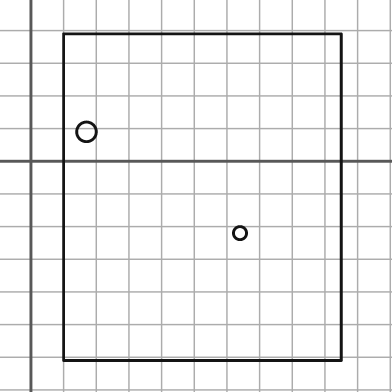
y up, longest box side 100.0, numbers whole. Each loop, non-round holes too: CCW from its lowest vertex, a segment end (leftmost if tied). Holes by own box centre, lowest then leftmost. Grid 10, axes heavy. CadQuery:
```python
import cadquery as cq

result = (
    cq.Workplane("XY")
    .moveTo(10.0, -61.0)
    .lineTo(95.0, -61.0)
    .lineTo(95.0, 39.0)
    .lineTo(10.0, 39.0)
    .close()
    .moveTo(64.0, -22.0)
    .circle(2.0)
    .moveTo(17.0, 9.0)
    .circle(3.0)
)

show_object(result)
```